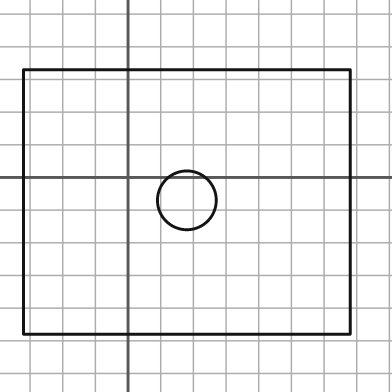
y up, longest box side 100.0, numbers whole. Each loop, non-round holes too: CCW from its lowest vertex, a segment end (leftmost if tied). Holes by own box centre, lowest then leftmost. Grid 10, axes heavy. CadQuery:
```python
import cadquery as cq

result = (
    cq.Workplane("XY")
    .moveTo(-32.0, -48.0)
    .lineTo(68.0, -48.0)
    .lineTo(68.0, 33.0)
    .lineTo(-32.0, 33.0)
    .close()
    .moveTo(18.0, -7.0)
    .circle(9.0)
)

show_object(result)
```